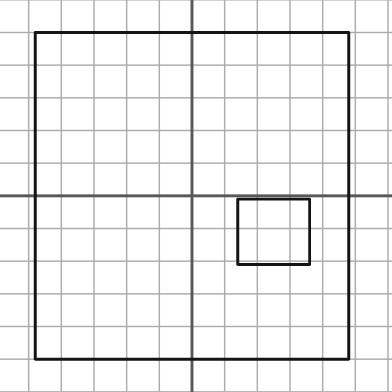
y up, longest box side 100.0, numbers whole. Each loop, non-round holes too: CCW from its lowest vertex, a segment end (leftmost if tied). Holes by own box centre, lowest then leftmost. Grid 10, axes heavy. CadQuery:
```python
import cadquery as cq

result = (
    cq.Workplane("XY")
    .moveTo(-48.0, -50.0)
    .lineTo(48.0, -50.0)
    .lineTo(48.0, 50.0)
    .lineTo(-48.0, 50.0)
    .close()
    .moveTo(14.0, -21.0)
    .lineTo(36.0, -21.0)
    .lineTo(36.0, -1.0)
    .lineTo(14.0, -1.0)
    .close()
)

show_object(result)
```